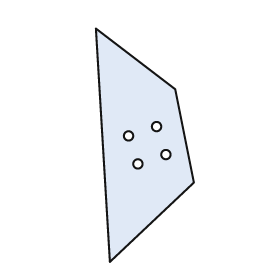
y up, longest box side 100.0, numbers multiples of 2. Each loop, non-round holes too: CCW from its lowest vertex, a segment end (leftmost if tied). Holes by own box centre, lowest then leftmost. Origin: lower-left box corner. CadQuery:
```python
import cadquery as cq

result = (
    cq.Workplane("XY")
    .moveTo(6.0, 0.0)
    .lineTo(42.0, 34.0)
    .lineTo(34.0, 74.0)
    .lineTo(0.0, 100.0)
    .close()
    .moveTo(18.0, 42.0)
    .circle(2.0)
    .moveTo(30.0, 46.0)
    .circle(2.0)
    .moveTo(14.0, 54.0)
    .circle(2.0)
    .moveTo(26.0, 58.0)
    .circle(2.0)
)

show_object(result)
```